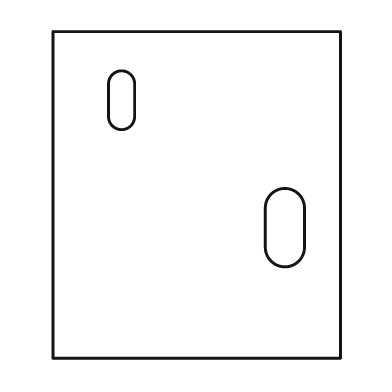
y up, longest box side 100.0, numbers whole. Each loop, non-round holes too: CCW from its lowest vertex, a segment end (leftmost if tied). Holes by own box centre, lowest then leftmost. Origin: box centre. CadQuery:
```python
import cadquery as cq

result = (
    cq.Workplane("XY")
    .moveTo(-44.0, -50.0)
    .lineTo(44.0, -50.0)
    .lineTo(44.0, 50.0)
    .lineTo(-44.0, 50.0)
    .close()
    .moveTo(21.0, -16.0)
    .threePointArc((27.0, -22.0), (33.0, -16.0))
    .lineTo(33.0, -4.0)
    .threePointArc((27.0, 2.0), (21.0, -4.0))
    .close()
    .moveTo(-27.0, 24.0)
    .threePointArc((-23.0, 20.0), (-19.0, 24.0))
    .lineTo(-19.0, 34.0)
    .threePointArc((-23.0, 38.0), (-27.0, 34.0))
    .close()
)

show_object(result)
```